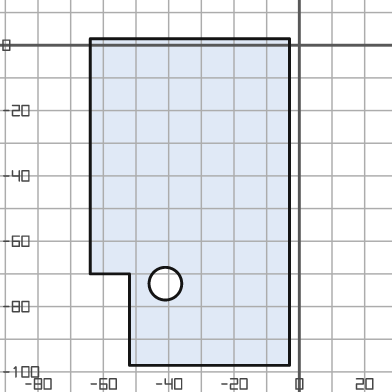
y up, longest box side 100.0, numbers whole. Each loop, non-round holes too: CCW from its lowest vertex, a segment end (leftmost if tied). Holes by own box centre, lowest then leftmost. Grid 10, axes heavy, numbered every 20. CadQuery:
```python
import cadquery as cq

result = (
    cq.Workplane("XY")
    .moveTo(-52.0, -98.0)
    .lineTo(-3.0, -98.0)
    .lineTo(-3.0, 2.0)
    .lineTo(-64.0, 2.0)
    .lineTo(-64.0, -70.0)
    .lineTo(-52.0, -70.0)
    .close()
    .moveTo(-41.0, -73.0)
    .circle(5.0)
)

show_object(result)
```